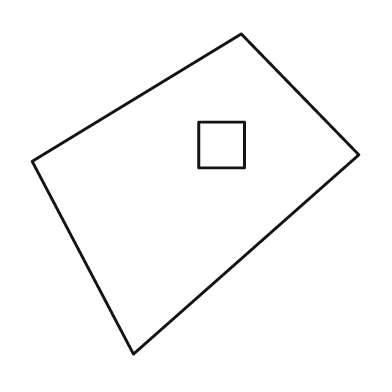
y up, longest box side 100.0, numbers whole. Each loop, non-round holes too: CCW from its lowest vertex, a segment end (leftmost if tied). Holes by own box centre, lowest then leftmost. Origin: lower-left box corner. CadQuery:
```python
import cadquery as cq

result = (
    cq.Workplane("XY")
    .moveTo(31.0, 0.0)
    .lineTo(100.0, 61.0)
    .lineTo(64.0, 98.0)
    .lineTo(0.0, 59.0)
    .close()
    .moveTo(51.0, 57.0)
    .lineTo(65.0, 57.0)
    .lineTo(65.0, 71.0)
    .lineTo(51.0, 71.0)
    .close()
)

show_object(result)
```